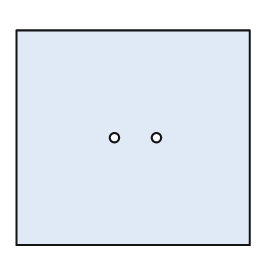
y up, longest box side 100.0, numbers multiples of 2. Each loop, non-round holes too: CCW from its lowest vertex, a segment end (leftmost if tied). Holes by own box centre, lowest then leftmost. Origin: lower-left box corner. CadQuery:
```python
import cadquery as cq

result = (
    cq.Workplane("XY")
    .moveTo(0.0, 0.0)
    .lineTo(100.0, 0.0)
    .lineTo(100.0, 92.0)
    .lineTo(0.0, 92.0)
    .close()
    .moveTo(42.0, 46.0)
    .circle(2.0)
    .moveTo(60.0, 46.0)
    .circle(2.0)
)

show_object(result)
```